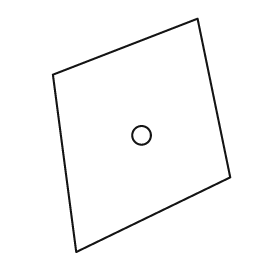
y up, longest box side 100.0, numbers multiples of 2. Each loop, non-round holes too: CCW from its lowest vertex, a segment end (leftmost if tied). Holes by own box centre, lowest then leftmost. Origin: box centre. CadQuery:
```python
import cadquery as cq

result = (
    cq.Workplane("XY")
    .moveTo(-28.0, -50.0)
    .lineTo(38.0, -18.0)
    .lineTo(24.0, 50.0)
    .lineTo(-38.0, 26.0)
    .close()
    .moveTo(0.0, 0.0)
    .circle(4.0)
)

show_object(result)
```